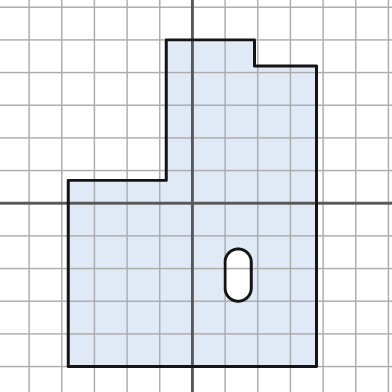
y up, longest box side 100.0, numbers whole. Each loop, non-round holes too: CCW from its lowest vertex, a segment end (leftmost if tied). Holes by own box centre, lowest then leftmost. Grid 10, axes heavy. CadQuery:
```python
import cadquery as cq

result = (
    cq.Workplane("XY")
    .moveTo(-38.0, -50.0)
    .lineTo(38.0, -50.0)
    .lineTo(38.0, 42.0)
    .lineTo(19.0, 42.0)
    .lineTo(19.0, 50.0)
    .lineTo(-8.0, 50.0)
    .lineTo(-8.0, 7.0)
    .lineTo(-38.0, 7.0)
    .close()
    .moveTo(10.0, -26.0)
    .threePointArc((14.0, -30.0), (18.0, -26.0))
    .lineTo(18.0, -18.0)
    .threePointArc((14.0, -14.0), (10.0, -18.0))
    .close()
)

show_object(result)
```